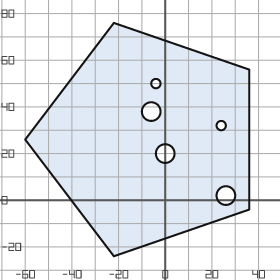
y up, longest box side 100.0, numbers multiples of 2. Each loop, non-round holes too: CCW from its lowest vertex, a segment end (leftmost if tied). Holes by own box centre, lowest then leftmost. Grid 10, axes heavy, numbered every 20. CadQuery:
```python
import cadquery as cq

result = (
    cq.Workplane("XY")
    .moveTo(-22.0, -24.0)
    .lineTo(36.0, -4.0)
    .lineTo(36.0, 56.0)
    .lineTo(-22.0, 76.0)
    .lineTo(-60.0, 26.0)
    .close()
    .moveTo(26.0, 2.0)
    .circle(4.0)
    .moveTo(0.0, 20.0)
    .circle(4.0)
    .moveTo(24.0, 32.0)
    .circle(2.0)
    .moveTo(-6.0, 38.0)
    .circle(4.0)
    .moveTo(-4.0, 50.0)
    .circle(2.0)
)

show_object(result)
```